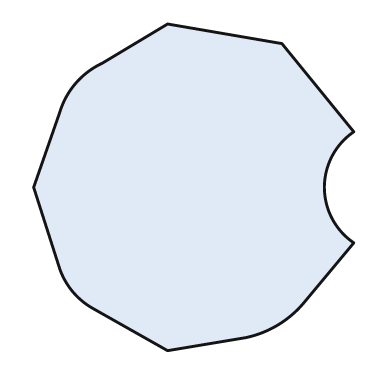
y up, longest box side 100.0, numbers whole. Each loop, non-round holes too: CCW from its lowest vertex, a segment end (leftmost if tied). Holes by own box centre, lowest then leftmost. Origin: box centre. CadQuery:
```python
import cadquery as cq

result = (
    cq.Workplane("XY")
    .moveTo(-8.0, -50.0)
    .lineTo(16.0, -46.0)
    .threePointArc((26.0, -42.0), (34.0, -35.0))
    .lineTo(49.0, -17.0)
    .threePointArc((40.0, 0.0), (49.0, 17.0))
    .lineTo(27.0, 44.0)
    .lineTo(-8.0, 50.0)
    .lineTo(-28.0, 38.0)
    .threePointArc((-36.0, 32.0), (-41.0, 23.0))
    .lineTo(-49.0, 0.0)
    .lineTo(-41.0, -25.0)
    .threePointArc((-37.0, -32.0), (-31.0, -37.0))
    .close()
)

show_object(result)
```